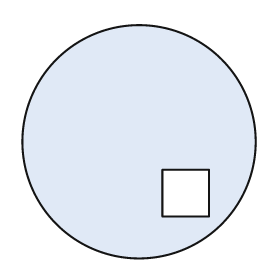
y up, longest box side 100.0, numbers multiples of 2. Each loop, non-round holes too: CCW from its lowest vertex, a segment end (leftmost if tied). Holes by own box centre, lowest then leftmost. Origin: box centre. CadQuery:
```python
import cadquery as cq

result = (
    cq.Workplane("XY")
    .moveTo(0.0, 0.0)
    .circle(50.0)
    .moveTo(10.0, -32.0)
    .lineTo(30.0, -32.0)
    .lineTo(30.0, -12.0)
    .lineTo(10.0, -12.0)
    .close()
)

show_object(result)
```